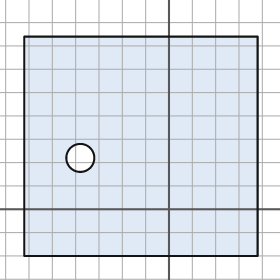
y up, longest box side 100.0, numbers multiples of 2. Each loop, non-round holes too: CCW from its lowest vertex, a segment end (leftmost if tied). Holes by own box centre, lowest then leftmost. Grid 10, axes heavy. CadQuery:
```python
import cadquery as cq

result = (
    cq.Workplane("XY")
    .moveTo(-62.0, -20.0)
    .lineTo(38.0, -20.0)
    .lineTo(38.0, 74.0)
    .lineTo(-62.0, 74.0)
    .close()
    .moveTo(-38.0, 22.0)
    .circle(6.0)
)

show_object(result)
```